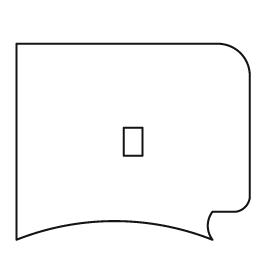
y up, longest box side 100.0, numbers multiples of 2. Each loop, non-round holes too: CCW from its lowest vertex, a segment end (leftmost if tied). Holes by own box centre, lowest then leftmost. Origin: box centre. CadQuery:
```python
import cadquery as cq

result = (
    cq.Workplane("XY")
    .moveTo(-50.0, -42.0)
    .threePointArc((-8.0, -34.0), (34.0, -42.0))
    .threePointArc((32.0, -36.0), (34.0, -30.0))
    .lineTo(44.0, -30.0)
    .threePointArc((48.0, -28.0), (50.0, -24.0))
    .lineTo(50.0, 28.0)
    .threePointArc((46.0, 38.0), (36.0, 42.0))
    .lineTo(-50.0, 42.0)
    .close()
    .moveTo(-4.0, -6.0)
    .lineTo(4.0, -6.0)
    .lineTo(4.0, 6.0)
    .lineTo(-4.0, 6.0)
    .close()
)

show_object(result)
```